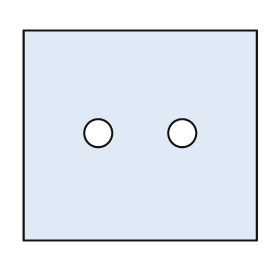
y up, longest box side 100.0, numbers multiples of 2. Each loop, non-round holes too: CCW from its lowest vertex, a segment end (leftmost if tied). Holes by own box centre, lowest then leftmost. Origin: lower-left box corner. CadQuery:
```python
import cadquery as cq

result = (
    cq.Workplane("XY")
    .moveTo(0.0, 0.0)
    .lineTo(100.0, 0.0)
    .lineTo(100.0, 90.0)
    .lineTo(0.0, 90.0)
    .close()
    .moveTo(32.0, 46.0)
    .circle(6.0)
    .moveTo(68.0, 46.0)
    .circle(6.0)
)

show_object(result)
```